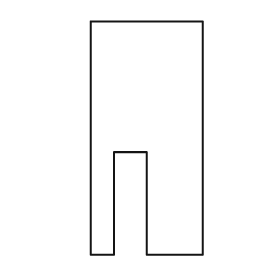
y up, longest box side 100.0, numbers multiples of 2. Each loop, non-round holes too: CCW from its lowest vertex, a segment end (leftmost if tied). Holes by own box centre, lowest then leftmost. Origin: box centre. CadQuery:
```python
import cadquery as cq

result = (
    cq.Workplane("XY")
    .moveTo(-24.0, -50.0)
    .lineTo(-14.0, -50.0)
    .lineTo(-14.0, -6.0)
    .lineTo(0.0, -6.0)
    .lineTo(0.0, -50.0)
    .lineTo(24.0, -50.0)
    .lineTo(24.0, 50.0)
    .lineTo(-24.0, 50.0)
    .close()
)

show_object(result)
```